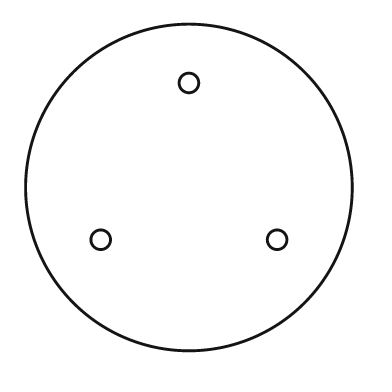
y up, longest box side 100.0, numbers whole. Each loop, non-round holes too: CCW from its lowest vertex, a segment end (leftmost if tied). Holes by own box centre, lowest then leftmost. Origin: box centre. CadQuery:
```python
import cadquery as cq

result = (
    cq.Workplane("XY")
    .moveTo(0.0, 0.0)
    .circle(50.0)
    .moveTo(-27.0, -16.0)
    .circle(3.0)
    .moveTo(27.0, -16.0)
    .circle(3.0)
    .moveTo(0.0, 32.0)
    .circle(3.0)
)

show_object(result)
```